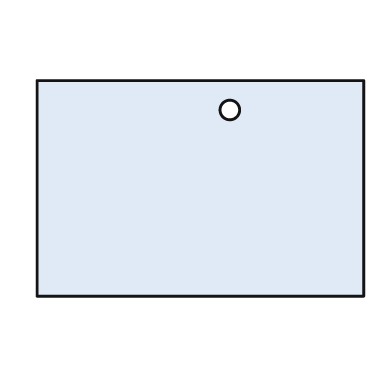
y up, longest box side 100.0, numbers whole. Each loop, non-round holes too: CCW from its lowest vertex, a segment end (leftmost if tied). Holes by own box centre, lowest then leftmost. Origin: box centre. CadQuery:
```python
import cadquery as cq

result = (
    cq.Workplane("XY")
    .moveTo(-50.0, -33.0)
    .lineTo(50.0, -33.0)
    .lineTo(50.0, 33.0)
    .lineTo(-50.0, 33.0)
    .close()
    .moveTo(9.0, 24.0)
    .circle(3.0)
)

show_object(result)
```